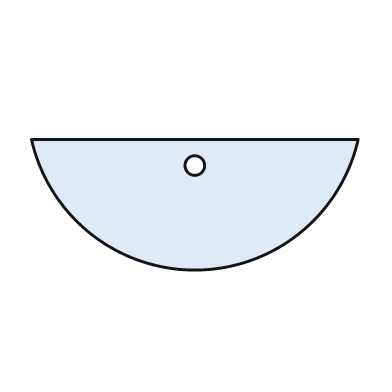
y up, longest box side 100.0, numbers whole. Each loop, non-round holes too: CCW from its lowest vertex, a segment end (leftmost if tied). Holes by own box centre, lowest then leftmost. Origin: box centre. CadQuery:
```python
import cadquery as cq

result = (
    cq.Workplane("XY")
    .moveTo(-50.0, 20.0)
    .threePointArc((0.0, -20.0), (50.0, 20.0))
    .close()
    .moveTo(0.0, 12.0)
    .circle(3.0)
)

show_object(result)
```